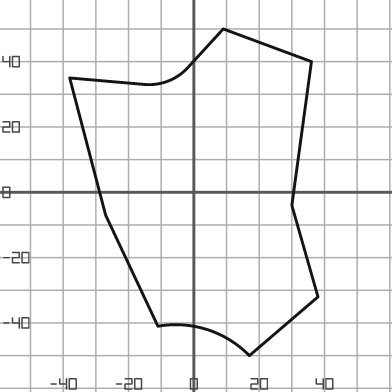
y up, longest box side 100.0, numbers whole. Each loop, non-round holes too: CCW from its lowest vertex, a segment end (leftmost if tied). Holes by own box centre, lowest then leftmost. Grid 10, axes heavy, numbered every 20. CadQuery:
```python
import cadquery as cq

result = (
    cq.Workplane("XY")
    .moveTo(17.0, -50.0)
    .lineTo(38.0, -32.0)
    .lineTo(30.0, -4.0)
    .lineTo(36.0, 40.0)
    .lineTo(9.0, 50.0)
    .lineTo(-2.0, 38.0)
    .threePointArc((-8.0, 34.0), (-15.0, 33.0))
    .lineTo(-38.0, 35.0)
    .lineTo(-27.0, -7.0)
    .lineTo(-11.0, -41.0)
    .threePointArc((4.0, -42.0), (17.0, -50.0))
    .close()
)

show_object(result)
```